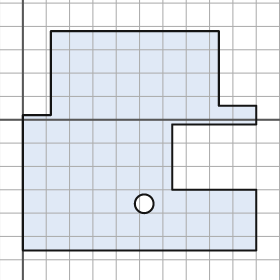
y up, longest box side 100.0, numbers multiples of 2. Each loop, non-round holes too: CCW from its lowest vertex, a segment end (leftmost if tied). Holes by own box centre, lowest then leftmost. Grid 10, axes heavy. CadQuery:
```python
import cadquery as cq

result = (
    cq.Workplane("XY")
    .moveTo(0.0, -56.0)
    .lineTo(100.0, -56.0)
    .lineTo(100.0, -30.0)
    .lineTo(64.0, -30.0)
    .lineTo(64.0, -2.0)
    .lineTo(100.0, -2.0)
    .lineTo(100.0, 6.0)
    .lineTo(84.0, 6.0)
    .lineTo(84.0, 38.0)
    .lineTo(12.0, 38.0)
    .lineTo(12.0, 2.0)
    .lineTo(0.0, 2.0)
    .close()
    .moveTo(52.0, -36.0)
    .circle(4.0)
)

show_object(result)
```